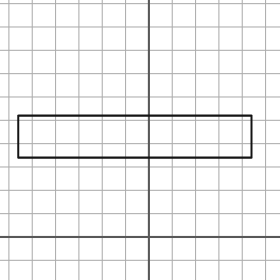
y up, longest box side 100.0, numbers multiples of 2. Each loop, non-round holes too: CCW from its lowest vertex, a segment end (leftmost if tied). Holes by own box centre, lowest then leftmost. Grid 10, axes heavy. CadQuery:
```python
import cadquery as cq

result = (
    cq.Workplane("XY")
    .moveTo(-56.0, 34.0)
    .lineTo(44.0, 34.0)
    .lineTo(44.0, 52.0)
    .lineTo(-56.0, 52.0)
    .close()
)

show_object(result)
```